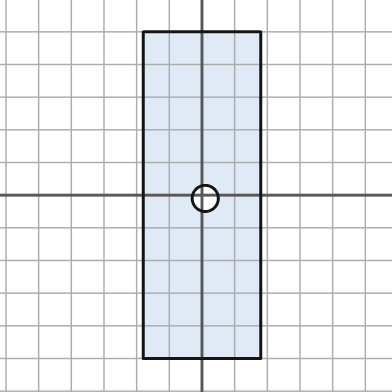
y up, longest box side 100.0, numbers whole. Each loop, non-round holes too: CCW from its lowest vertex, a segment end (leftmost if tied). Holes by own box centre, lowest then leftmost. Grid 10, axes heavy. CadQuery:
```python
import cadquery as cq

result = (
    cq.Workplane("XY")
    .moveTo(-18.0, -50.0)
    .lineTo(18.0, -50.0)
    .lineTo(18.0, 50.0)
    .lineTo(-18.0, 50.0)
    .close()
    .moveTo(1.0, -1.0)
    .circle(4.0)
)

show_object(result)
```